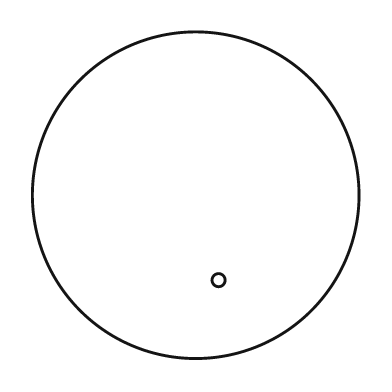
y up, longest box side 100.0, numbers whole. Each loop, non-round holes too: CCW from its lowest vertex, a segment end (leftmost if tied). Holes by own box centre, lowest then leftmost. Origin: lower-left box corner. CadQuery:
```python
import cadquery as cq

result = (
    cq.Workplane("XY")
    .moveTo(50.0, 50.0)
    .circle(50.0)
    .moveTo(57.0, 24.0)
    .circle(2.0)
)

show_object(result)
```